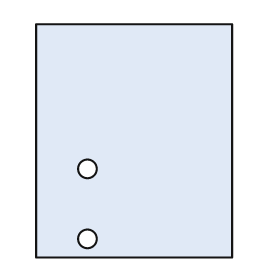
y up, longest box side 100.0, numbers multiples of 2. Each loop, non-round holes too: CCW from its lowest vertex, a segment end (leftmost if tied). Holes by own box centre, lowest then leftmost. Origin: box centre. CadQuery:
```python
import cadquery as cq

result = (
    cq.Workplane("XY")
    .moveTo(-42.0, -50.0)
    .lineTo(42.0, -50.0)
    .lineTo(42.0, 50.0)
    .lineTo(-42.0, 50.0)
    .close()
    .moveTo(-20.0, -42.0)
    .circle(4.0)
    .moveTo(-20.0, -12.0)
    .circle(4.0)
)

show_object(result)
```